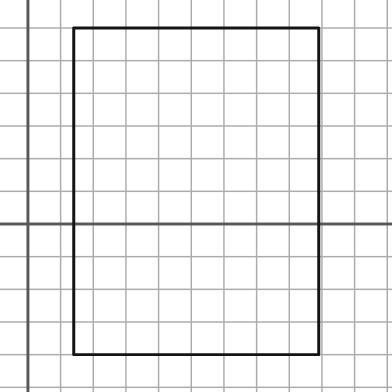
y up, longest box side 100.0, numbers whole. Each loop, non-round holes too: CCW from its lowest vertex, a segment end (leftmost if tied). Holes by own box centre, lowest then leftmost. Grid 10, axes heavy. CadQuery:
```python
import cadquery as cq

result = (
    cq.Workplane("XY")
    .moveTo(14.0, -40.0)
    .lineTo(89.0, -40.0)
    .lineTo(89.0, 60.0)
    .lineTo(14.0, 60.0)
    .close()
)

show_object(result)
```